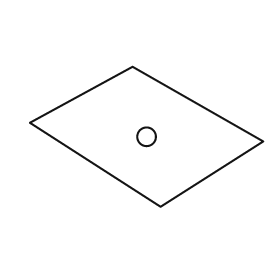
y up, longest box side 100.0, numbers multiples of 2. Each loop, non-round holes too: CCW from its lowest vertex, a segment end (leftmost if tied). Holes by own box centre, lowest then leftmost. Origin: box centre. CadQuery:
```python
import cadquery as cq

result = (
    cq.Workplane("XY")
    .moveTo(6.0, -30.0)
    .lineTo(50.0, -2.0)
    .lineTo(-6.0, 30.0)
    .lineTo(-50.0, 6.0)
    .close()
    .moveTo(0.0, 0.0)
    .circle(4.0)
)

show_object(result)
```